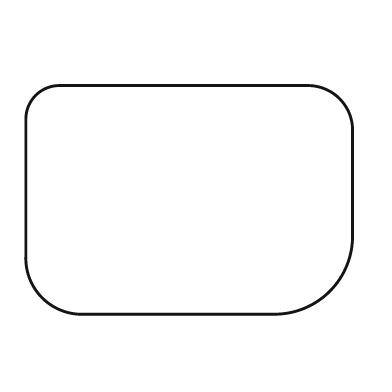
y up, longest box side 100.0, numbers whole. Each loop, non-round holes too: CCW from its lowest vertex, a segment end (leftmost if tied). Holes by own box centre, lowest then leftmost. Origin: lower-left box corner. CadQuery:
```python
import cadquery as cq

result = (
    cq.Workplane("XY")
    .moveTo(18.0, 0.0)
    .lineTo(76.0, 0.0)
    .threePointArc((93.0, 7.0), (100.0, 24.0))
    .lineTo(100.0, 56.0)
    .threePointArc((96.0, 66.0), (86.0, 70.0))
    .lineTo(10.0, 70.0)
    .threePointArc((3.0, 67.0), (0.0, 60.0))
    .lineTo(0.0, 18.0)
    .threePointArc((5.0, 5.0), (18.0, 0.0))
    .close()
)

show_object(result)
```